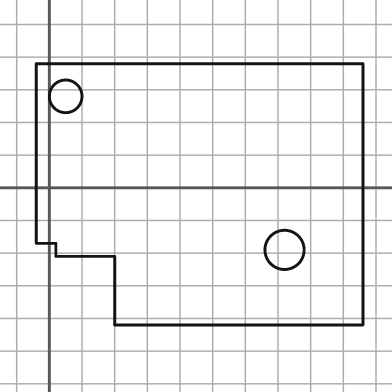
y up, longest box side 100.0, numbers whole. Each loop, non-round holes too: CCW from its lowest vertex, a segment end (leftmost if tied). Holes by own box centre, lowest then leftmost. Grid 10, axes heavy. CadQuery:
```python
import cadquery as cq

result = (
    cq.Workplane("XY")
    .moveTo(20.0, -42.0)
    .lineTo(96.0, -42.0)
    .lineTo(96.0, 38.0)
    .lineTo(-4.0, 38.0)
    .lineTo(-4.0, -17.0)
    .lineTo(2.0, -17.0)
    .lineTo(2.0, -21.0)
    .lineTo(20.0, -21.0)
    .close()
    .moveTo(72.0, -19.0)
    .circle(6.0)
    .moveTo(5.0, 28.0)
    .circle(5.0)
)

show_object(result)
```